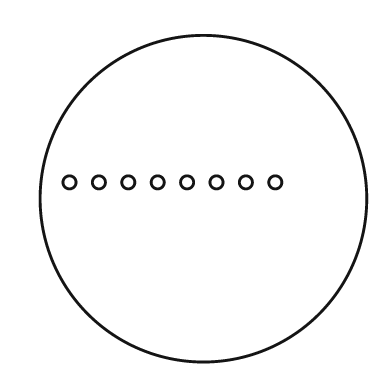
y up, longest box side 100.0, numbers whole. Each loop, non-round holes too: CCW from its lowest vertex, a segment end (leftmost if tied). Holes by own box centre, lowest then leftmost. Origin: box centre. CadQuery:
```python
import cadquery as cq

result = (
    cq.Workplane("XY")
    .moveTo(0.0, 0.0)
    .circle(50.0)
    .moveTo(-41.0, 5.0)
    .circle(2.0)
    .moveTo(-32.0, 5.0)
    .circle(2.0)
    .moveTo(-23.0, 5.0)
    .circle(2.0)
    .moveTo(-14.0, 5.0)
    .circle(2.0)
    .moveTo(-5.0, 5.0)
    .circle(2.0)
    .moveTo(4.0, 5.0)
    .circle(2.0)
    .moveTo(13.0, 5.0)
    .circle(2.0)
    .moveTo(22.0, 5.0)
    .circle(2.0)
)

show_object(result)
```